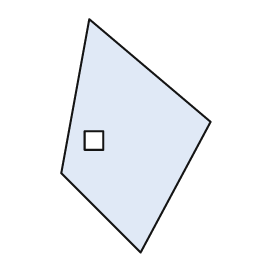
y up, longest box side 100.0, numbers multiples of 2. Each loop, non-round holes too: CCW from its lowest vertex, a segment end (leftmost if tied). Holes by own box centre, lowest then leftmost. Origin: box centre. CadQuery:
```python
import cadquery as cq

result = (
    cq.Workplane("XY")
    .moveTo(2.0, -50.0)
    .lineTo(32.0, 6.0)
    .lineTo(-20.0, 50.0)
    .lineTo(-32.0, -16.0)
    .close()
    .moveTo(-22.0, -6.0)
    .lineTo(-14.0, -6.0)
    .lineTo(-14.0, 2.0)
    .lineTo(-22.0, 2.0)
    .close()
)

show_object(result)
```